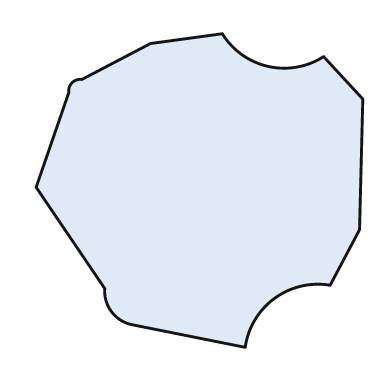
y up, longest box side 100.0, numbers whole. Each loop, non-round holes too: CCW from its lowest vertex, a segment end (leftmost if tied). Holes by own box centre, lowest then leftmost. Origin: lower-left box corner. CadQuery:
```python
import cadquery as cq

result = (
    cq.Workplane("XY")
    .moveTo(64.0, 0.0)
    .threePointArc((73.0, 15.0), (90.0, 19.0))
    .lineTo(99.0, 36.0)
    .lineTo(100.0, 76.0)
    .lineTo(88.0, 89.0)
    .threePointArc((71.0, 86.0), (57.0, 96.0))
    .lineTo(35.0, 93.0)
    .lineTo(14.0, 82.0)
    .threePointArc((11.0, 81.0), (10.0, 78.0))
    .lineTo(0.0, 49.0)
    .lineTo(21.0, 18.0)
    .threePointArc((23.0, 11.0), (29.0, 7.0))
    .close()
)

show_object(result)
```